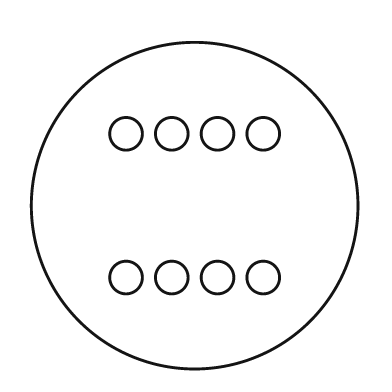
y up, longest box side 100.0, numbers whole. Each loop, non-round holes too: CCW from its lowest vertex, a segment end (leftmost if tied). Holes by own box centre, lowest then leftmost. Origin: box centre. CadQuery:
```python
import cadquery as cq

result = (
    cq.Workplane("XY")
    .moveTo(0.0, 0.0)
    .circle(50.0)
    .moveTo(-21.0, -22.0)
    .circle(5.0)
    .moveTo(-7.0, -22.0)
    .circle(5.0)
    .moveTo(7.0, -22.0)
    .circle(5.0)
    .moveTo(21.0, -22.0)
    .circle(5.0)
    .moveTo(-21.0, 22.0)
    .circle(5.0)
    .moveTo(-7.0, 22.0)
    .circle(5.0)
    .moveTo(7.0, 22.0)
    .circle(5.0)
    .moveTo(21.0, 22.0)
    .circle(5.0)
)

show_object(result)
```